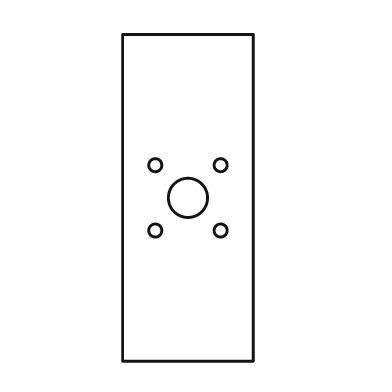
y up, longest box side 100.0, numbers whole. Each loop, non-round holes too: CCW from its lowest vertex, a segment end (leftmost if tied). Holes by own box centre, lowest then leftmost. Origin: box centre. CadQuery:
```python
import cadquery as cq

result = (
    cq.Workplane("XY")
    .moveTo(-20.0, -50.0)
    .lineTo(20.0, -50.0)
    .lineTo(20.0, 50.0)
    .lineTo(-20.0, 50.0)
    .close()
    .moveTo(-10.0, -10.0)
    .circle(2.0)
    .moveTo(10.0, -10.0)
    .circle(2.0)
    .moveTo(0.0, 0.0)
    .circle(6.0)
    .moveTo(-10.0, 10.0)
    .circle(2.0)
    .moveTo(10.0, 10.0)
    .circle(2.0)
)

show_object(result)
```